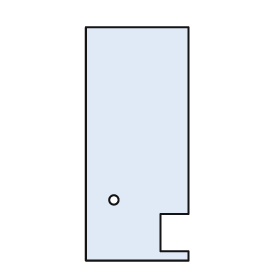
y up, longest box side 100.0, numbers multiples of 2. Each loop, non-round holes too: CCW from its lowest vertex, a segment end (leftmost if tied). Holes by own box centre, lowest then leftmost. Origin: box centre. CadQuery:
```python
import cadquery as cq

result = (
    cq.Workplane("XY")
    .moveTo(-22.0, -50.0)
    .lineTo(22.0, -50.0)
    .lineTo(22.0, -46.0)
    .lineTo(10.0, -46.0)
    .lineTo(10.0, -30.0)
    .lineTo(22.0, -30.0)
    .lineTo(22.0, 50.0)
    .lineTo(-22.0, 50.0)
    .close()
    .moveTo(-10.0, -24.0)
    .circle(2.0)
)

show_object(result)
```